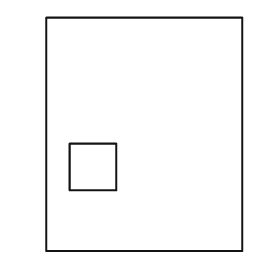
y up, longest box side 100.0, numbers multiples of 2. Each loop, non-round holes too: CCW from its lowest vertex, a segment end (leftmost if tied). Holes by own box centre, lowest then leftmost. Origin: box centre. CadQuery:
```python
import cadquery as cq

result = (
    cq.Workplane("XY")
    .moveTo(-42.0, -50.0)
    .lineTo(42.0, -50.0)
    .lineTo(42.0, 50.0)
    .lineTo(-42.0, 50.0)
    .close()
    .moveTo(-32.0, -24.0)
    .lineTo(-12.0, -24.0)
    .lineTo(-12.0, -4.0)
    .lineTo(-32.0, -4.0)
    .close()
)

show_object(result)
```